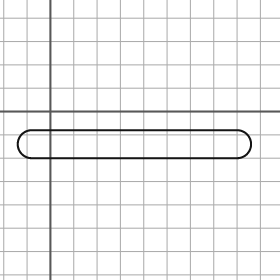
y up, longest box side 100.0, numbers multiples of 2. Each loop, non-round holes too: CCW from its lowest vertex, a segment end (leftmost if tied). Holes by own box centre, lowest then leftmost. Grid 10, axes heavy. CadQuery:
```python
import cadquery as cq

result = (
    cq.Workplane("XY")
    .moveTo(-8.0, -20.0)
    .lineTo(80.0, -20.0)
    .threePointArc((86.0, -14.0), (80.0, -8.0))
    .lineTo(-8.0, -8.0)
    .threePointArc((-14.0, -14.0), (-8.0, -20.0))
    .close()
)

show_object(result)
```